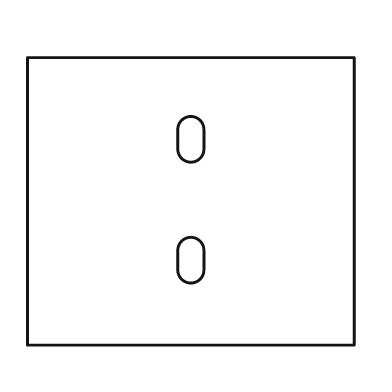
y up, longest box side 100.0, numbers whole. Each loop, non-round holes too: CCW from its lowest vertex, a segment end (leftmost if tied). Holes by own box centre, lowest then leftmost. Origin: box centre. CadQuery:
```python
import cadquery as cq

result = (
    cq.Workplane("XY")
    .moveTo(-50.0, -44.0)
    .lineTo(50.0, -44.0)
    .lineTo(50.0, 44.0)
    .lineTo(-50.0, 44.0)
    .close()
    .moveTo(-4.0, -21.0)
    .threePointArc((0.0, -25.0), (4.0, -21.0))
    .lineTo(4.0, -15.0)
    .threePointArc((0.0, -11.0), (-4.0, -15.0))
    .close()
    .moveTo(-4.0, 16.0)
    .threePointArc((0.0, 12.0), (4.0, 16.0))
    .lineTo(4.0, 22.0)
    .threePointArc((0.0, 26.0), (-4.0, 22.0))
    .close()
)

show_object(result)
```